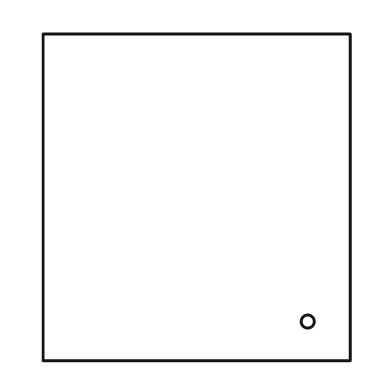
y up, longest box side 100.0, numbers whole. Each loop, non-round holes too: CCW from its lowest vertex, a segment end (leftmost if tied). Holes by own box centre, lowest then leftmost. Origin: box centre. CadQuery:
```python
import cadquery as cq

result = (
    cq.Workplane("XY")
    .moveTo(-47.0, -50.0)
    .lineTo(47.0, -50.0)
    .lineTo(47.0, 50.0)
    .lineTo(-47.0, 50.0)
    .close()
    .moveTo(34.0, -38.0)
    .circle(2.0)
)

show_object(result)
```